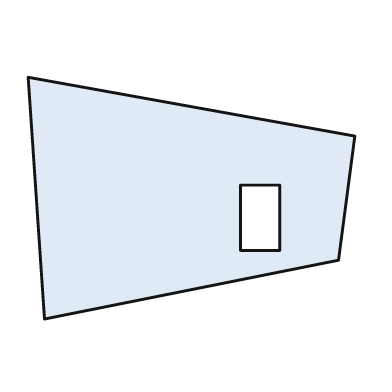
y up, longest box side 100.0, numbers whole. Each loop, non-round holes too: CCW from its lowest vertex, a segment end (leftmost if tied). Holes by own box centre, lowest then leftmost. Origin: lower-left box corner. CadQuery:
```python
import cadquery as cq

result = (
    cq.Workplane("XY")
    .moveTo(5.0, 0.0)
    .lineTo(95.0, 18.0)
    .lineTo(100.0, 56.0)
    .lineTo(0.0, 74.0)
    .close()
    .moveTo(65.0, 21.0)
    .lineTo(77.0, 21.0)
    .lineTo(77.0, 41.0)
    .lineTo(65.0, 41.0)
    .close()
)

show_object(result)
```